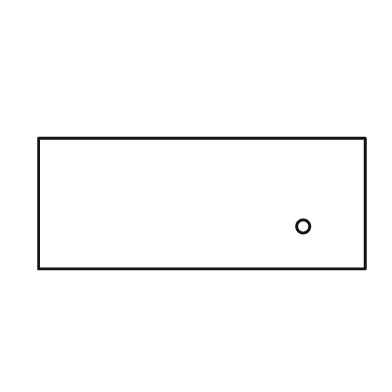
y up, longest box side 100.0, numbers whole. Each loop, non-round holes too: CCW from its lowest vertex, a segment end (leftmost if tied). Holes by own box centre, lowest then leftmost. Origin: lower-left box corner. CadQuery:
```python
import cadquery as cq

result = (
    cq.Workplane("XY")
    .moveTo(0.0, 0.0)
    .lineTo(100.0, 0.0)
    .lineTo(100.0, 40.0)
    .lineTo(0.0, 40.0)
    .close()
    .moveTo(81.0, 13.0)
    .circle(2.0)
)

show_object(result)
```